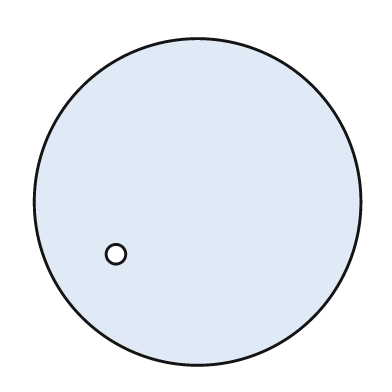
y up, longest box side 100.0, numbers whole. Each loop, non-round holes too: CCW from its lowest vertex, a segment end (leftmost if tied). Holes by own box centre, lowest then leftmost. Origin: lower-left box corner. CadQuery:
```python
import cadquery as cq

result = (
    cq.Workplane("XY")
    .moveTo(50.0, 50.0)
    .circle(50.0)
    .moveTo(25.0, 34.0)
    .circle(3.0)
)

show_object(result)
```